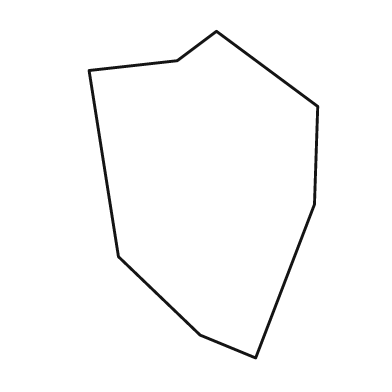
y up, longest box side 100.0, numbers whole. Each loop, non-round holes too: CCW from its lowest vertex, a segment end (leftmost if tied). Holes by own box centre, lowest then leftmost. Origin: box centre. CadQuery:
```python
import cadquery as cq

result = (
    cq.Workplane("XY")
    .moveTo(16.0, -50.0)
    .lineTo(34.0, -3.0)
    .lineTo(35.0, 27.0)
    .lineTo(4.0, 50.0)
    .lineTo(-8.0, 41.0)
    .lineTo(-35.0, 38.0)
    .lineTo(-26.0, -19.0)
    .lineTo(-1.0, -43.0)
    .close()
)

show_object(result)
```